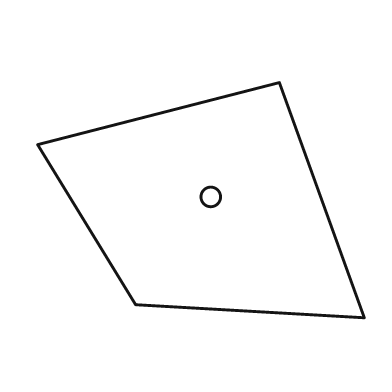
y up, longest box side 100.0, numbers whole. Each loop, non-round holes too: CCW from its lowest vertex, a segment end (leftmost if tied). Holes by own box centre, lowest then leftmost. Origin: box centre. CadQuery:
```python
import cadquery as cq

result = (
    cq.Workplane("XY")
    .moveTo(50.0, -36.0)
    .lineTo(24.0, 36.0)
    .lineTo(-50.0, 17.0)
    .lineTo(-20.0, -32.0)
    .close()
    .moveTo(3.0, 1.0)
    .circle(3.0)
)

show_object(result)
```